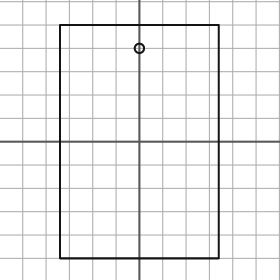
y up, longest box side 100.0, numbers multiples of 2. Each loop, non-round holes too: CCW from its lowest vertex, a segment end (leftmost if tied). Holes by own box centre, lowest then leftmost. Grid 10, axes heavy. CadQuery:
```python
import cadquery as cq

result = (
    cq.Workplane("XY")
    .moveTo(-34.0, -50.0)
    .lineTo(34.0, -50.0)
    .lineTo(34.0, 50.0)
    .lineTo(-34.0, 50.0)
    .close()
    .moveTo(0.0, 40.0)
    .circle(2.0)
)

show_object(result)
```